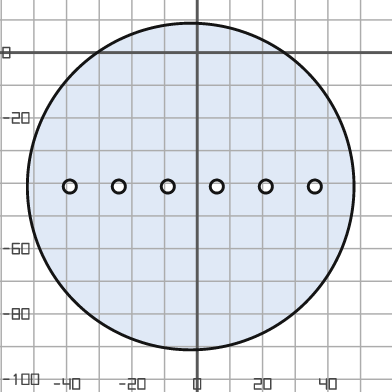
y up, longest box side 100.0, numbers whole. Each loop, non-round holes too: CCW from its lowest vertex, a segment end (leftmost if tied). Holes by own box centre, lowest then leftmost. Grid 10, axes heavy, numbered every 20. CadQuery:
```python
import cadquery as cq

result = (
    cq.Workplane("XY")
    .moveTo(-2.0, -41.0)
    .circle(50.0)
    .moveTo(-39.0, -41.0)
    .circle(2.0)
    .moveTo(-24.0, -41.0)
    .circle(2.0)
    .moveTo(-9.0, -41.0)
    .circle(2.0)
    .moveTo(6.0, -41.0)
    .circle(2.0)
    .moveTo(21.0, -41.0)
    .circle(2.0)
    .moveTo(36.0, -41.0)
    .circle(2.0)
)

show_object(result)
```